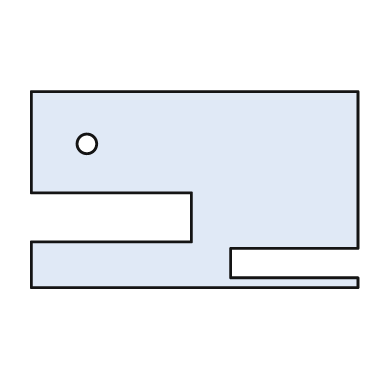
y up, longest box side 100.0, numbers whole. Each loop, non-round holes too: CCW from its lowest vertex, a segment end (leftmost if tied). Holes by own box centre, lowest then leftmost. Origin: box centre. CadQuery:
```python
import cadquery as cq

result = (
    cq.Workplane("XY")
    .moveTo(-50.0, -30.0)
    .lineTo(50.0, -30.0)
    .lineTo(50.0, -27.0)
    .lineTo(11.0, -27.0)
    .lineTo(11.0, -18.0)
    .lineTo(50.0, -18.0)
    .lineTo(50.0, 30.0)
    .lineTo(-50.0, 30.0)
    .lineTo(-50.0, -1.0)
    .lineTo(-1.0, -1.0)
    .lineTo(-1.0, -16.0)
    .lineTo(-50.0, -16.0)
    .close()
    .moveTo(-33.0, 14.0)
    .circle(3.0)
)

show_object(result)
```